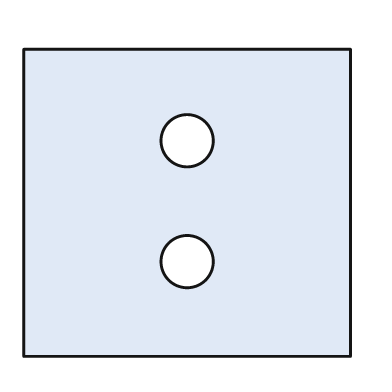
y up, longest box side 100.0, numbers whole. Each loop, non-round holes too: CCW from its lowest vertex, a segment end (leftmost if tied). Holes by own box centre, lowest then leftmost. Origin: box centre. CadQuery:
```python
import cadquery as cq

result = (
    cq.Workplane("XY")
    .moveTo(-50.0, -47.0)
    .lineTo(50.0, -47.0)
    .lineTo(50.0, 47.0)
    .lineTo(-50.0, 47.0)
    .close()
    .moveTo(0.0, -18.0)
    .circle(8.0)
    .moveTo(0.0, 19.0)
    .circle(8.0)
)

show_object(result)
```